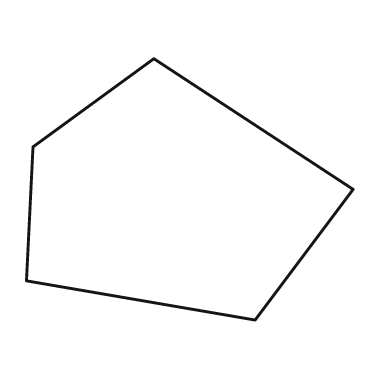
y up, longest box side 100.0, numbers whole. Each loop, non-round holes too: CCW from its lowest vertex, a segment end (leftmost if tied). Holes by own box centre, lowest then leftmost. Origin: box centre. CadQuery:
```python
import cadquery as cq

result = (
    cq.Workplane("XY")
    .moveTo(20.0, -40.0)
    .lineTo(50.0, 0.0)
    .lineTo(-11.0, 40.0)
    .lineTo(-48.0, 13.0)
    .lineTo(-50.0, -28.0)
    .close()
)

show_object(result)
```